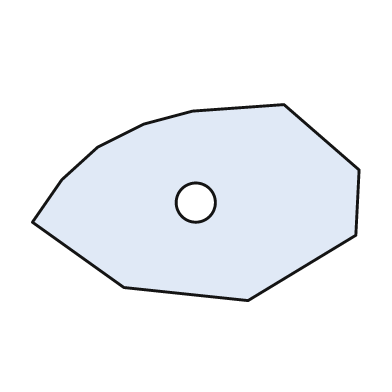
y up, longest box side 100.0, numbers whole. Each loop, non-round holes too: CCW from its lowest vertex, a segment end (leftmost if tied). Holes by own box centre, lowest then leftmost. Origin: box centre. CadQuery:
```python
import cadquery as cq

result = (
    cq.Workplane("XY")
    .moveTo(16.0, -30.0)
    .lineTo(49.0, -10.0)
    .lineTo(50.0, 10.0)
    .lineTo(27.0, 30.0)
    .lineTo(-1.0, 28.0)
    .lineTo(-16.0, 24.0)
    .lineTo(-30.0, 17.0)
    .lineTo(-41.0, 7.0)
    .lineTo(-50.0, -6.0)
    .lineTo(-22.0, -26.0)
    .close()
    .moveTo(0.0, 0.0)
    .circle(6.0)
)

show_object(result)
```